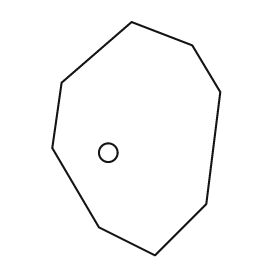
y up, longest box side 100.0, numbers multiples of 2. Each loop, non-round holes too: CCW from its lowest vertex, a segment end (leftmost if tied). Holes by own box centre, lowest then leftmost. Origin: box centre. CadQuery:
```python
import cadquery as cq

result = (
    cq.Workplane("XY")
    .moveTo(8.0, -50.0)
    .lineTo(30.0, -28.0)
    .lineTo(36.0, 20.0)
    .lineTo(24.0, 40.0)
    .lineTo(-2.0, 50.0)
    .lineTo(-32.0, 24.0)
    .lineTo(-36.0, -4.0)
    .lineTo(-16.0, -38.0)
    .close()
    .moveTo(-12.0, -6.0)
    .circle(4.0)
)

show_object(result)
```